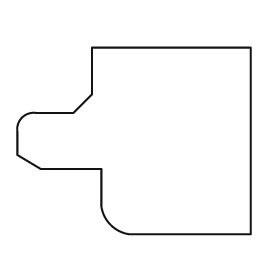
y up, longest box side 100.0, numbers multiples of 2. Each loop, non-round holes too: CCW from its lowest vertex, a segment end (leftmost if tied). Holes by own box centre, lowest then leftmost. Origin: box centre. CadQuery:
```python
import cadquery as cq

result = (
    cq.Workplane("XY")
    .moveTo(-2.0, -40.0)
    .lineTo(50.0, -40.0)
    .lineTo(50.0, 40.0)
    .lineTo(-18.0, 40.0)
    .lineTo(-18.0, 20.0)
    .lineTo(-26.0, 12.0)
    .lineTo(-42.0, 12.0)
    .threePointArc((-48.0, 10.0), (-50.0, 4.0))
    .lineTo(-50.0, -6.0)
    .lineTo(-40.0, -12.0)
    .lineTo(-14.0, -12.0)
    .lineTo(-14.0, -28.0)
    .threePointArc((-10.0, -36.0), (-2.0, -40.0))
    .close()
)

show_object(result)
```